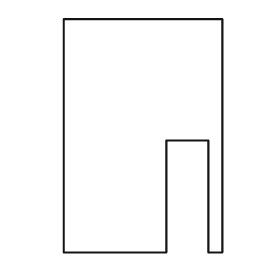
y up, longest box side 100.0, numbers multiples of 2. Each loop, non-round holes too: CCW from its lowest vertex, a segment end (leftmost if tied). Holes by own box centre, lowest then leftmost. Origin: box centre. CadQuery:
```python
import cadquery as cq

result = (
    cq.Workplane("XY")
    .moveTo(-34.0, -50.0)
    .lineTo(10.0, -50.0)
    .lineTo(10.0, -2.0)
    .lineTo(28.0, -2.0)
    .lineTo(28.0, -50.0)
    .lineTo(34.0, -50.0)
    .lineTo(34.0, 50.0)
    .lineTo(-34.0, 50.0)
    .close()
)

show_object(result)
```